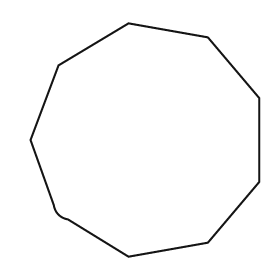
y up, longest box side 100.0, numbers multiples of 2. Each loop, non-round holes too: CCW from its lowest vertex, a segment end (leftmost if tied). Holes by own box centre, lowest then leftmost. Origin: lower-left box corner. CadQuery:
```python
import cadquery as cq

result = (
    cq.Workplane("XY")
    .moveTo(42.0, 0.0)
    .lineTo(76.0, 6.0)
    .lineTo(98.0, 32.0)
    .lineTo(98.0, 68.0)
    .lineTo(76.0, 94.0)
    .lineTo(42.0, 100.0)
    .lineTo(12.0, 82.0)
    .lineTo(0.0, 50.0)
    .lineTo(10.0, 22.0)
    .threePointArc((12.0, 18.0), (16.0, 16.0))
    .close()
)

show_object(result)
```